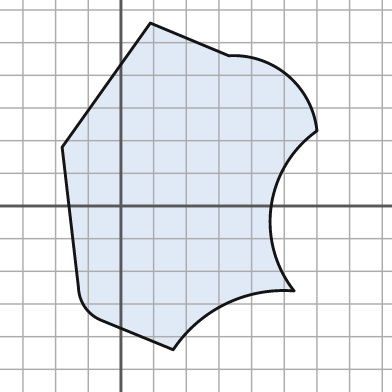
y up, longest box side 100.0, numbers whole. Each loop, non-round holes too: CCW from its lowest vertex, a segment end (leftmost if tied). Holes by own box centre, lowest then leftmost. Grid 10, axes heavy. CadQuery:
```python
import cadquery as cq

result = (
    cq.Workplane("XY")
    .moveTo(16.0, -44.0)
    .threePointArc((32.0, -30.0), (53.0, -26.0))
    .threePointArc((46.0, 0.0), (60.0, 23.0))
    .threePointArc((51.0, 40.0), (33.0, 46.0))
    .lineTo(9.0, 56.0)
    .lineTo(-18.0, 18.0)
    .lineTo(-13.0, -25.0)
    .threePointArc((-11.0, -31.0), (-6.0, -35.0))
    .close()
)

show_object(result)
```